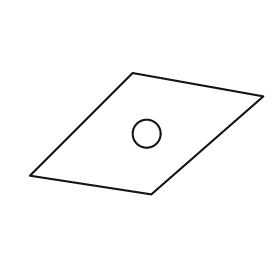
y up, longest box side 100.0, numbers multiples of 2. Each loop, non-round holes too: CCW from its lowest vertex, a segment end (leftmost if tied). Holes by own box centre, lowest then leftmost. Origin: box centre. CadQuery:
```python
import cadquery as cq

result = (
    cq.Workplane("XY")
    .moveTo(2.0, -26.0)
    .lineTo(50.0, 16.0)
    .lineTo(-6.0, 26.0)
    .lineTo(-50.0, -18.0)
    .close()
    .moveTo(0.0, 0.0)
    .circle(6.0)
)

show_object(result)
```